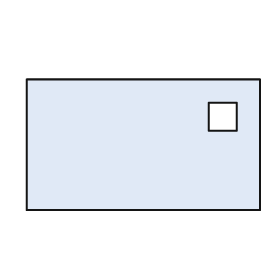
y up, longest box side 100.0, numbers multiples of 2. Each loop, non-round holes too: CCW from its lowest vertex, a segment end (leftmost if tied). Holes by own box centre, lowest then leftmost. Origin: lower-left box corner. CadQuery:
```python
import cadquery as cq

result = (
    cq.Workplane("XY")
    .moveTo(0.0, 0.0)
    .lineTo(100.0, 0.0)
    .lineTo(100.0, 56.0)
    .lineTo(0.0, 56.0)
    .close()
    .moveTo(78.0, 34.0)
    .lineTo(90.0, 34.0)
    .lineTo(90.0, 46.0)
    .lineTo(78.0, 46.0)
    .close()
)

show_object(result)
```